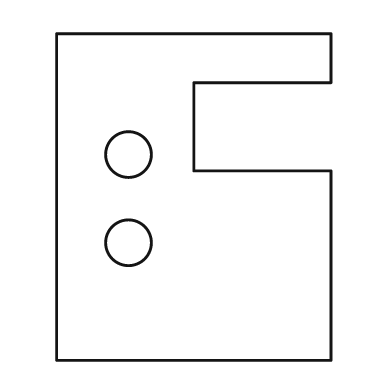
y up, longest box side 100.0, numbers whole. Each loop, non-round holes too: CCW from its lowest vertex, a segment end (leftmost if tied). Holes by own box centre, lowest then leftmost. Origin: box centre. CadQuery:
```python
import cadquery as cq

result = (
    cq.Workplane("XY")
    .moveTo(-42.0, -50.0)
    .lineTo(42.0, -50.0)
    .lineTo(42.0, 8.0)
    .lineTo(0.0, 8.0)
    .lineTo(0.0, 35.0)
    .lineTo(42.0, 35.0)
    .lineTo(42.0, 50.0)
    .lineTo(-42.0, 50.0)
    .close()
    .moveTo(-20.0, -14.0)
    .circle(7.0)
    .moveTo(-20.0, 13.0)
    .circle(7.0)
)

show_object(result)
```